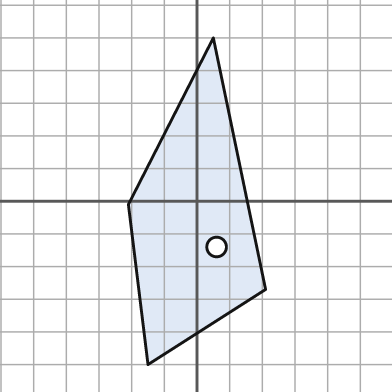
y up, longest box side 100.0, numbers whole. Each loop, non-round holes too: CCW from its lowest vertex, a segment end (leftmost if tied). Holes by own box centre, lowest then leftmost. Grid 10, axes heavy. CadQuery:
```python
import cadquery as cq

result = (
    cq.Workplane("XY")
    .moveTo(-15.0, -50.0)
    .lineTo(21.0, -27.0)
    .lineTo(5.0, 50.0)
    .lineTo(-21.0, -1.0)
    .close()
    .moveTo(6.0, -14.0)
    .circle(3.0)
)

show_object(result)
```